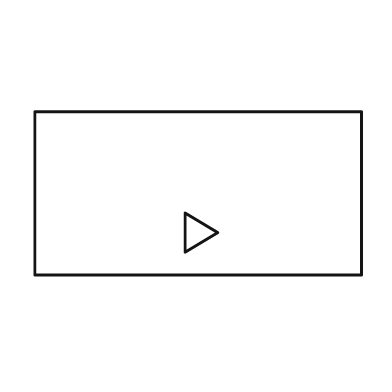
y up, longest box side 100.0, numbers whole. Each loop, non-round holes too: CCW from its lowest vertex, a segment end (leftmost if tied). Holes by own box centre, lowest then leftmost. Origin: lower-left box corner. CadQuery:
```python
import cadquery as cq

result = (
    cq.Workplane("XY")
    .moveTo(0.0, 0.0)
    .lineTo(100.0, 0.0)
    .lineTo(100.0, 50.0)
    .lineTo(0.0, 50.0)
    .close()
    .moveTo(46.0, 7.0)
    .lineTo(56.0, 13.0)
    .lineTo(46.0, 19.0)
    .close()
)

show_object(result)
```